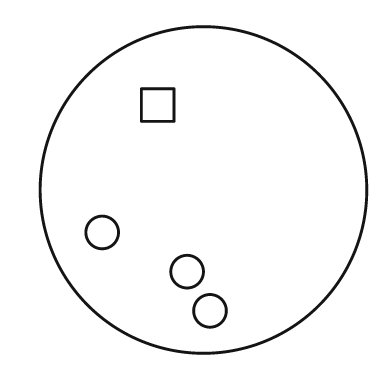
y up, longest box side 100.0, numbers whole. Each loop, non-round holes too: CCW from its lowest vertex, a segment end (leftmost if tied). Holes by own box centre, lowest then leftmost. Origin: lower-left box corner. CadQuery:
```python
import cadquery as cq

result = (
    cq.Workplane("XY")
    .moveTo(50.0, 50.0)
    .circle(50.0)
    .moveTo(52.0, 13.0)
    .circle(5.0)
    .moveTo(45.0, 25.0)
    .circle(5.0)
    .moveTo(19.0, 37.0)
    .circle(5.0)
    .moveTo(31.0, 71.0)
    .lineTo(41.0, 71.0)
    .lineTo(41.0, 81.0)
    .lineTo(31.0, 81.0)
    .close()
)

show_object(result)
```